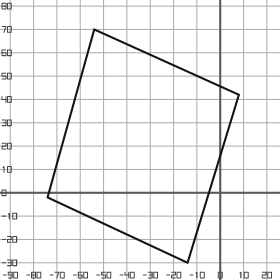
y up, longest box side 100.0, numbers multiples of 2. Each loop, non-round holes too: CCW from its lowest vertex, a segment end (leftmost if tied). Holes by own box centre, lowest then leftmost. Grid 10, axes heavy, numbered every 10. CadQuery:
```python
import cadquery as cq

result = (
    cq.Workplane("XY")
    .moveTo(-14.0, -30.0)
    .lineTo(8.0, 42.0)
    .lineTo(-54.0, 70.0)
    .lineTo(-74.0, -2.0)
    .close()
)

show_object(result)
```